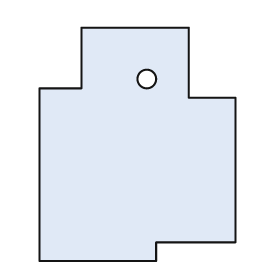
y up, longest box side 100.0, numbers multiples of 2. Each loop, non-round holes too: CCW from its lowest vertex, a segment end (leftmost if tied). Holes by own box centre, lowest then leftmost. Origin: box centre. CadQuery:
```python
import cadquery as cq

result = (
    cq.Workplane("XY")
    .moveTo(-42.0, -50.0)
    .lineTo(8.0, -50.0)
    .lineTo(8.0, -42.0)
    .lineTo(42.0, -42.0)
    .lineTo(42.0, 20.0)
    .lineTo(22.0, 20.0)
    .lineTo(22.0, 50.0)
    .lineTo(-24.0, 50.0)
    .lineTo(-24.0, 24.0)
    .lineTo(-42.0, 24.0)
    .close()
    .moveTo(4.0, 28.0)
    .circle(4.0)
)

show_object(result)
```